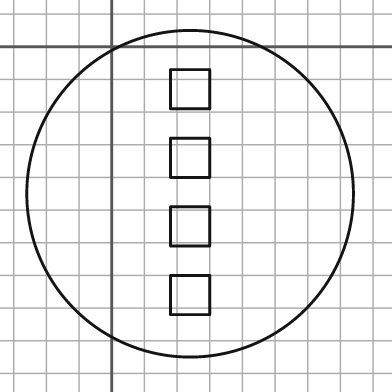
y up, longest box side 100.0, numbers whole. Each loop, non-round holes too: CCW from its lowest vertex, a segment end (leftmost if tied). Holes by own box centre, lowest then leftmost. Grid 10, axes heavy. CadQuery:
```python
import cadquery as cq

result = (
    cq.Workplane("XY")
    .moveTo(24.0, -45.0)
    .circle(50.0)
    .moveTo(18.0, -82.0)
    .lineTo(30.0, -82.0)
    .lineTo(30.0, -70.0)
    .lineTo(18.0, -70.0)
    .close()
    .moveTo(18.0, -61.0)
    .lineTo(30.0, -61.0)
    .lineTo(30.0, -49.0)
    .lineTo(18.0, -49.0)
    .close()
    .moveTo(18.0, -40.0)
    .lineTo(30.0, -40.0)
    .lineTo(30.0, -28.0)
    .lineTo(18.0, -28.0)
    .close()
    .moveTo(18.0, -19.0)
    .lineTo(30.0, -19.0)
    .lineTo(30.0, -7.0)
    .lineTo(18.0, -7.0)
    .close()
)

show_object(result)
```